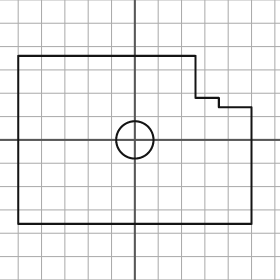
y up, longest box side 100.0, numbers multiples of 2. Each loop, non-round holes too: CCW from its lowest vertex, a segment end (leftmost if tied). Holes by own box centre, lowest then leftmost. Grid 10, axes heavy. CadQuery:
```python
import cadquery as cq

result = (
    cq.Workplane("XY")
    .moveTo(-50.0, -36.0)
    .lineTo(50.0, -36.0)
    .lineTo(50.0, 14.0)
    .lineTo(36.0, 14.0)
    .lineTo(36.0, 18.0)
    .lineTo(26.0, 18.0)
    .lineTo(26.0, 36.0)
    .lineTo(-50.0, 36.0)
    .close()
    .moveTo(0.0, 0.0)
    .circle(8.0)
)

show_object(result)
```